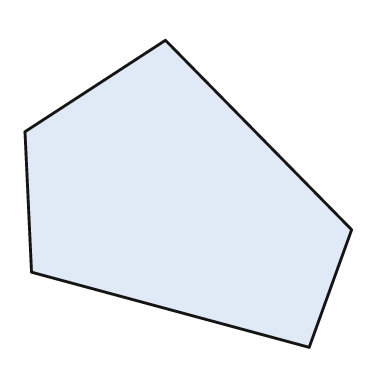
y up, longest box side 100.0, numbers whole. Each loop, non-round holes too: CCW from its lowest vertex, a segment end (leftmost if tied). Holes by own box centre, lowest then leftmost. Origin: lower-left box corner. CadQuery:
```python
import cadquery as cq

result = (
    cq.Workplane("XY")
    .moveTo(87.0, 0.0)
    .lineTo(100.0, 36.0)
    .lineTo(43.0, 94.0)
    .lineTo(0.0, 66.0)
    .lineTo(2.0, 23.0)
    .close()
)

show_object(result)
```